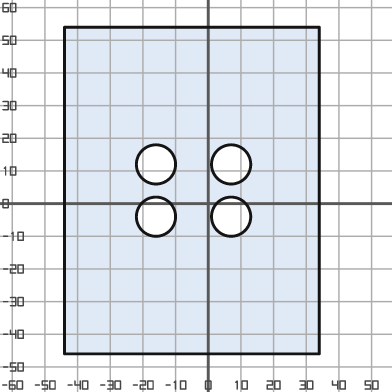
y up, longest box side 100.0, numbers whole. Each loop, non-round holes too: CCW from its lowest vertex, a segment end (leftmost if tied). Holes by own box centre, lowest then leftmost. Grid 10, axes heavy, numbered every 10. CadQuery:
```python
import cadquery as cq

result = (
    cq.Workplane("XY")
    .moveTo(-44.0, -46.0)
    .lineTo(34.0, -46.0)
    .lineTo(34.0, 54.0)
    .lineTo(-44.0, 54.0)
    .close()
    .moveTo(-16.0, -4.0)
    .circle(6.0)
    .moveTo(7.0, -4.0)
    .circle(6.0)
    .moveTo(-16.0, 12.0)
    .circle(6.0)
    .moveTo(7.0, 12.0)
    .circle(6.0)
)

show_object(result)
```